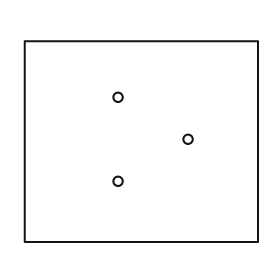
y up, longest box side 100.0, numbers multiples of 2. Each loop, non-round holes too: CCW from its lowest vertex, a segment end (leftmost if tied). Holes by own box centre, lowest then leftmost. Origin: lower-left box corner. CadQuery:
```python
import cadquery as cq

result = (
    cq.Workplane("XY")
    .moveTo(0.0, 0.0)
    .lineTo(100.0, 0.0)
    .lineTo(100.0, 86.0)
    .lineTo(0.0, 86.0)
    .close()
    .moveTo(40.0, 26.0)
    .circle(2.0)
    .moveTo(70.0, 44.0)
    .circle(2.0)
    .moveTo(40.0, 62.0)
    .circle(2.0)
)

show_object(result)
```